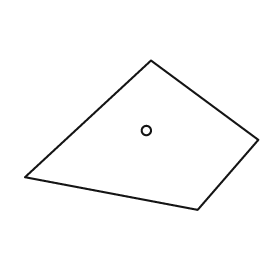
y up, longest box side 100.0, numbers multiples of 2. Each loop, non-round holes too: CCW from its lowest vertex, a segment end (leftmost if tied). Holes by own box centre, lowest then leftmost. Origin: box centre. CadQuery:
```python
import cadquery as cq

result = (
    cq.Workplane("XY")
    .moveTo(24.0, -32.0)
    .lineTo(50.0, -2.0)
    .lineTo(4.0, 32.0)
    .lineTo(-50.0, -18.0)
    .close()
    .moveTo(2.0, 2.0)
    .circle(2.0)
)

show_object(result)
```